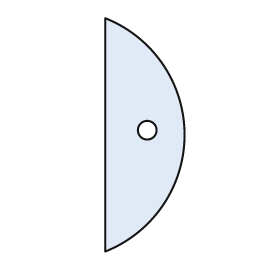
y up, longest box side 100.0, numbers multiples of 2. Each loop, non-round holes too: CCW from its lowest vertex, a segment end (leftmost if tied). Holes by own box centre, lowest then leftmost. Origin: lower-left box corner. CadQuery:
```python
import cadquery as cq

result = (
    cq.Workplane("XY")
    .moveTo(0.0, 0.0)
    .threePointArc((34.0, 50.0), (0.0, 100.0))
    .close()
    .moveTo(18.0, 52.0)
    .circle(4.0)
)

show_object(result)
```